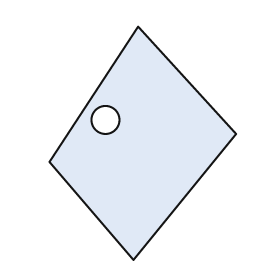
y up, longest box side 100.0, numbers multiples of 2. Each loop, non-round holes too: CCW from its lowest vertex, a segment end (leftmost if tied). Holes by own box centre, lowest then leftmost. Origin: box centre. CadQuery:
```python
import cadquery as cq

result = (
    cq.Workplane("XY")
    .moveTo(-4.0, -50.0)
    .lineTo(40.0, 4.0)
    .lineTo(-2.0, 50.0)
    .lineTo(-40.0, -8.0)
    .close()
    .moveTo(-16.0, 10.0)
    .circle(6.0)
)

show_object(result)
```